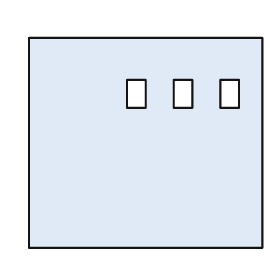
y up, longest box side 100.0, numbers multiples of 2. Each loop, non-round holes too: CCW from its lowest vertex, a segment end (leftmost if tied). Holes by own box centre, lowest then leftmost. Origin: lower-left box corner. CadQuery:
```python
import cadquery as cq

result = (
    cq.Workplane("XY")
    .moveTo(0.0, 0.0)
    .lineTo(100.0, 0.0)
    .lineTo(100.0, 90.0)
    .lineTo(0.0, 90.0)
    .close()
    .moveTo(42.0, 60.0)
    .lineTo(50.0, 60.0)
    .lineTo(50.0, 72.0)
    .lineTo(42.0, 72.0)
    .close()
    .moveTo(62.0, 60.0)
    .lineTo(70.0, 60.0)
    .lineTo(70.0, 72.0)
    .lineTo(62.0, 72.0)
    .close()
    .moveTo(82.0, 60.0)
    .lineTo(90.0, 60.0)
    .lineTo(90.0, 72.0)
    .lineTo(82.0, 72.0)
    .close()
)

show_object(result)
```